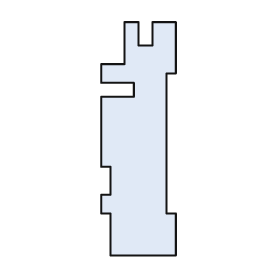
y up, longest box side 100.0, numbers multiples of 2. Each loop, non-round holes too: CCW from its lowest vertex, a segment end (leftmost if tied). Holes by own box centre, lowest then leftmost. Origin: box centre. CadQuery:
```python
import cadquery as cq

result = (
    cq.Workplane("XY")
    .moveTo(-12.0, -50.0)
    .lineTo(16.0, -50.0)
    .lineTo(16.0, -32.0)
    .lineTo(12.0, -32.0)
    .lineTo(12.0, 28.0)
    .lineTo(16.0, 28.0)
    .lineTo(16.0, 50.0)
    .lineTo(6.0, 50.0)
    .lineTo(6.0, 40.0)
    .lineTo(0.0, 40.0)
    .lineTo(0.0, 50.0)
    .lineTo(-6.0, 50.0)
    .lineTo(-6.0, 32.0)
    .lineTo(-16.0, 32.0)
    .lineTo(-16.0, 24.0)
    .lineTo(-2.0, 24.0)
    .lineTo(-2.0, 18.0)
    .lineTo(-16.0, 18.0)
    .lineTo(-16.0, -12.0)
    .lineTo(-12.0, -12.0)
    .lineTo(-12.0, -24.0)
    .lineTo(-16.0, -24.0)
    .lineTo(-16.0, -32.0)
    .lineTo(-12.0, -32.0)
    .close()
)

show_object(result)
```